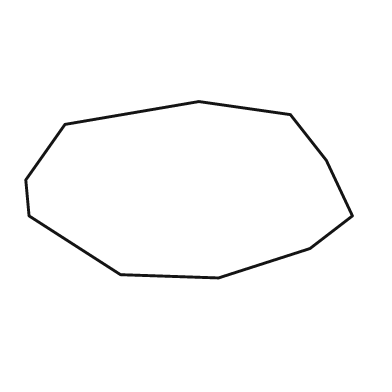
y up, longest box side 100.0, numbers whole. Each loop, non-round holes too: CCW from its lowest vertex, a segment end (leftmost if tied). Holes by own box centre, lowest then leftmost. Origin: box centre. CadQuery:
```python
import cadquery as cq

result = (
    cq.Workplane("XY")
    .moveTo(9.0, -27.0)
    .lineTo(37.0, -18.0)
    .lineTo(50.0, -8.0)
    .lineTo(42.0, 9.0)
    .lineTo(31.0, 23.0)
    .lineTo(3.0, 27.0)
    .lineTo(-38.0, 20.0)
    .lineTo(-50.0, 3.0)
    .lineTo(-49.0, -8.0)
    .lineTo(-21.0, -26.0)
    .close()
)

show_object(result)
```